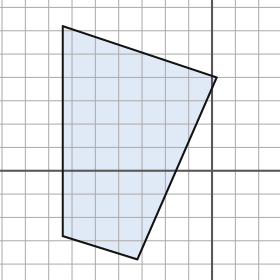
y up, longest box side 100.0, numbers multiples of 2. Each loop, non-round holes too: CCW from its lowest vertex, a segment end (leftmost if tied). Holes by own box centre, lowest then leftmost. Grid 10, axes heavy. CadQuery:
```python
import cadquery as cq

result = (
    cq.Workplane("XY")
    .moveTo(-32.0, -38.0)
    .lineTo(2.0, 40.0)
    .lineTo(-64.0, 62.0)
    .lineTo(-64.0, -28.0)
    .close()
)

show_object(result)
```